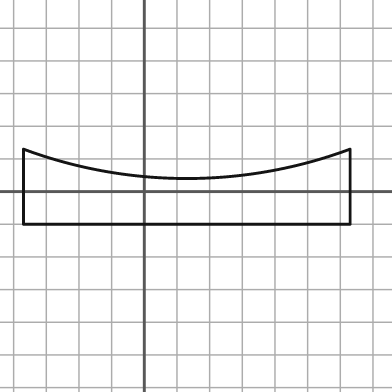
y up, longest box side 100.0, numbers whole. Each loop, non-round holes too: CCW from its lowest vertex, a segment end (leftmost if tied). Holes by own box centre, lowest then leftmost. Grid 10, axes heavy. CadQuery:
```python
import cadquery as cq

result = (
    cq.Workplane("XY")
    .moveTo(-37.0, -10.0)
    .lineTo(63.0, -10.0)
    .lineTo(63.0, 13.0)
    .threePointArc((13.0, 4.0), (-37.0, 13.0))
    .close()
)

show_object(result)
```